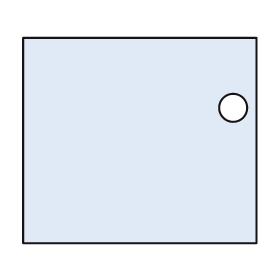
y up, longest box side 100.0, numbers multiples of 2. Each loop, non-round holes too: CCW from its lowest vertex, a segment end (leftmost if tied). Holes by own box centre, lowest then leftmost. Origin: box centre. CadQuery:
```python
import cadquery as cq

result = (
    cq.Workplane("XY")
    .moveTo(-50.0, -44.0)
    .lineTo(50.0, -44.0)
    .lineTo(50.0, 44.0)
    .lineTo(-50.0, 44.0)
    .close()
    .moveTo(40.0, 14.0)
    .circle(6.0)
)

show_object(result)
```